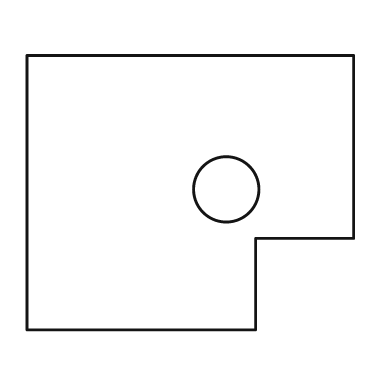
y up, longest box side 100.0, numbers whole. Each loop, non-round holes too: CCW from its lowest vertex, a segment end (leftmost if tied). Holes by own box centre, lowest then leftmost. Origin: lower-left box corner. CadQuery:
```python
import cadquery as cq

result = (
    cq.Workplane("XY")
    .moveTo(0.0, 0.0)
    .lineTo(70.0, 0.0)
    .lineTo(70.0, 28.0)
    .lineTo(100.0, 28.0)
    .lineTo(100.0, 84.0)
    .lineTo(0.0, 84.0)
    .close()
    .moveTo(61.0, 43.0)
    .circle(10.0)
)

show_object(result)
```